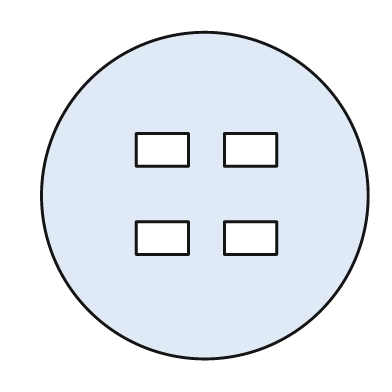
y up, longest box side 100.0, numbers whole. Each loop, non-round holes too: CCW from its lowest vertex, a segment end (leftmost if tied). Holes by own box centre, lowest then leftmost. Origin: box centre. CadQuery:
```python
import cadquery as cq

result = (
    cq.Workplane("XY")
    .moveTo(0.0, 0.0)
    .circle(50.0)
    .moveTo(-21.0, -18.0)
    .lineTo(-5.0, -18.0)
    .lineTo(-5.0, -8.0)
    .lineTo(-21.0, -8.0)
    .close()
    .moveTo(6.0, -18.0)
    .lineTo(22.0, -18.0)
    .lineTo(22.0, -8.0)
    .lineTo(6.0, -8.0)
    .close()
    .moveTo(-21.0, 9.0)
    .lineTo(-5.0, 9.0)
    .lineTo(-5.0, 19.0)
    .lineTo(-21.0, 19.0)
    .close()
    .moveTo(6.0, 9.0)
    .lineTo(22.0, 9.0)
    .lineTo(22.0, 19.0)
    .lineTo(6.0, 19.0)
    .close()
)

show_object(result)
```